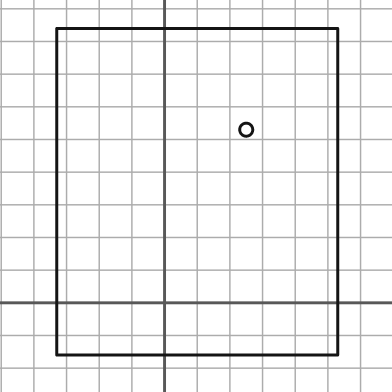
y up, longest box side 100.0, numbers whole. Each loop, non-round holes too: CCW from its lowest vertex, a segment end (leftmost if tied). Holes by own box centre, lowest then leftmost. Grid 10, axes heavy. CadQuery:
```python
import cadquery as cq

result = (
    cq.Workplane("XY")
    .moveTo(-33.0, -16.0)
    .lineTo(53.0, -16.0)
    .lineTo(53.0, 84.0)
    .lineTo(-33.0, 84.0)
    .close()
    .moveTo(25.0, 53.0)
    .circle(2.0)
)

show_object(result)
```